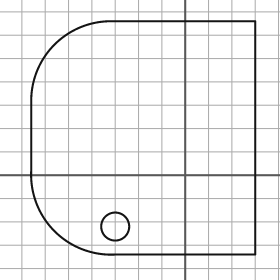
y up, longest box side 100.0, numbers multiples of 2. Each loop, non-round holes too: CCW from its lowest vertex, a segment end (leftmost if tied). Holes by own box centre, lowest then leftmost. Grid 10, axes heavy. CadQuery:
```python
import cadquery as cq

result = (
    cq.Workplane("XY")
    .moveTo(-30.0, -34.0)
    .lineTo(30.0, -34.0)
    .lineTo(30.0, 66.0)
    .lineTo(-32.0, 66.0)
    .threePointArc((-56.0, 56.0), (-66.0, 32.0))
    .lineTo(-66.0, 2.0)
    .threePointArc((-56.0, -24.0), (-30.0, -34.0))
    .close()
    .moveTo(-30.0, -22.0)
    .circle(6.0)
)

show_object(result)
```